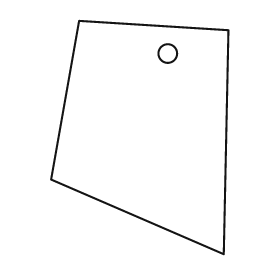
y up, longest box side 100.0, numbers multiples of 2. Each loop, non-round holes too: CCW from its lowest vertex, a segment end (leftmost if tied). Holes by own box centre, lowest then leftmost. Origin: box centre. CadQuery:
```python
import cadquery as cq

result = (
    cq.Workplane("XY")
    .moveTo(36.0, -50.0)
    .lineTo(38.0, 46.0)
    .lineTo(-26.0, 50.0)
    .lineTo(-38.0, -18.0)
    .close()
    .moveTo(12.0, 36.0)
    .circle(4.0)
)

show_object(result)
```